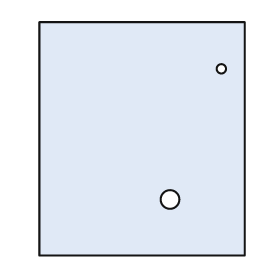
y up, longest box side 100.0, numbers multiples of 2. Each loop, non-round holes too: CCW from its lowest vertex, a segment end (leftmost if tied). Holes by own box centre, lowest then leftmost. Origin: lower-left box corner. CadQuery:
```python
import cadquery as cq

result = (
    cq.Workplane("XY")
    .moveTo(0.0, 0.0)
    .lineTo(88.0, 0.0)
    .lineTo(88.0, 100.0)
    .lineTo(0.0, 100.0)
    .close()
    .moveTo(56.0, 24.0)
    .circle(4.0)
    .moveTo(78.0, 80.0)
    .circle(2.0)
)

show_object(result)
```